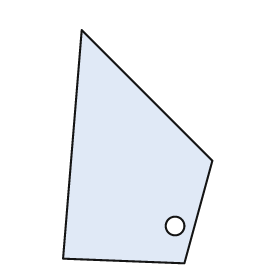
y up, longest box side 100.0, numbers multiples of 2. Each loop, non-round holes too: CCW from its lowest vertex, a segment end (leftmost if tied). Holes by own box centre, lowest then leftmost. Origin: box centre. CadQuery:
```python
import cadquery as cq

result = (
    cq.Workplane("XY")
    .moveTo(20.0, -50.0)
    .lineTo(32.0, -6.0)
    .lineTo(-24.0, 50.0)
    .lineTo(-32.0, -48.0)
    .close()
    .moveTo(16.0, -34.0)
    .circle(4.0)
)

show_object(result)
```